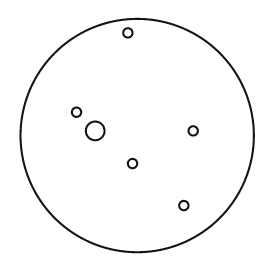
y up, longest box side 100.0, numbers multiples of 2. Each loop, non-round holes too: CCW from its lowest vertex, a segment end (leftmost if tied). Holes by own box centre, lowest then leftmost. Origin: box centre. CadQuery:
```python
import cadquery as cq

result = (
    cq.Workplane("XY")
    .moveTo(0.0, 0.0)
    .circle(50.0)
    .moveTo(20.0, -30.0)
    .circle(2.0)
    .moveTo(-2.0, -12.0)
    .circle(2.0)
    .moveTo(-18.0, 2.0)
    .circle(4.0)
    .moveTo(24.0, 2.0)
    .circle(2.0)
    .moveTo(-26.0, 10.0)
    .circle(2.0)
    .moveTo(-4.0, 44.0)
    .circle(2.0)
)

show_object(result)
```